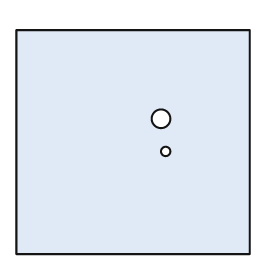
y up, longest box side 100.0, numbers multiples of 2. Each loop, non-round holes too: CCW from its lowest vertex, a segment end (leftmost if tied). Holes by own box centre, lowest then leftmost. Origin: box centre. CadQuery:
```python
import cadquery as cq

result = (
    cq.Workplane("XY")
    .moveTo(-50.0, -48.0)
    .lineTo(50.0, -48.0)
    .lineTo(50.0, 48.0)
    .lineTo(-50.0, 48.0)
    .close()
    .moveTo(14.0, -4.0)
    .circle(2.0)
    .moveTo(12.0, 10.0)
    .circle(4.0)
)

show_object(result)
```